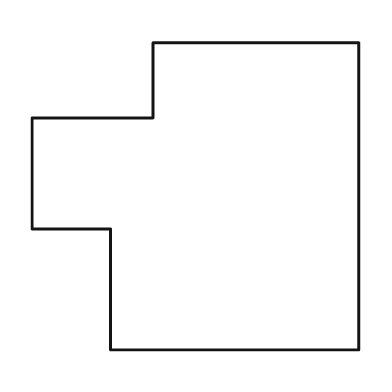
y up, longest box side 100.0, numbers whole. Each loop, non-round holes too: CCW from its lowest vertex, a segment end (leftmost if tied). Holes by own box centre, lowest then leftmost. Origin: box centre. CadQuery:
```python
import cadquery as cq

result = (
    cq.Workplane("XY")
    .moveTo(-26.0, -47.0)
    .lineTo(50.0, -47.0)
    .lineTo(50.0, 47.0)
    .lineTo(-13.0, 47.0)
    .lineTo(-13.0, 24.0)
    .lineTo(-50.0, 24.0)
    .lineTo(-50.0, -10.0)
    .lineTo(-26.0, -10.0)
    .close()
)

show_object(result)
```